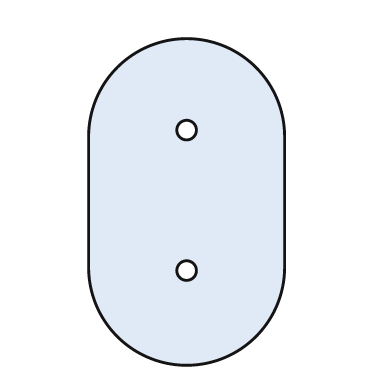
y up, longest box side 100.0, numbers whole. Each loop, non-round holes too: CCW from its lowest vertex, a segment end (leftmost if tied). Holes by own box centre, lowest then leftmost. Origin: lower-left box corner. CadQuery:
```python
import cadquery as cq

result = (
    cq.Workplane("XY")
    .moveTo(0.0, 30.0)
    .threePointArc((30.0, 0.0), (60.0, 30.0))
    .lineTo(60.0, 70.0)
    .threePointArc((30.0, 100.0), (0.0, 70.0))
    .close()
    .moveTo(30.0, 29.0)
    .circle(3.0)
    .moveTo(30.0, 72.0)
    .circle(3.0)
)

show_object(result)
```